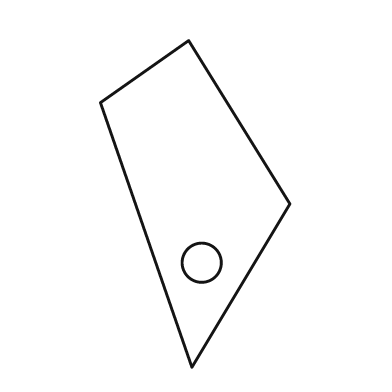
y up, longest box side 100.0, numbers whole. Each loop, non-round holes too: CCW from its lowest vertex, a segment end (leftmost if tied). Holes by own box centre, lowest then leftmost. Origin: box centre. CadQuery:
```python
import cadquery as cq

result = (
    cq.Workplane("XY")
    .moveTo(-1.0, -50.0)
    .lineTo(29.0, 0.0)
    .lineTo(-2.0, 50.0)
    .lineTo(-29.0, 31.0)
    .close()
    .moveTo(2.0, -18.0)
    .circle(6.0)
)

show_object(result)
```